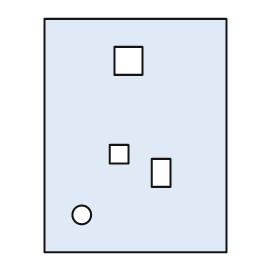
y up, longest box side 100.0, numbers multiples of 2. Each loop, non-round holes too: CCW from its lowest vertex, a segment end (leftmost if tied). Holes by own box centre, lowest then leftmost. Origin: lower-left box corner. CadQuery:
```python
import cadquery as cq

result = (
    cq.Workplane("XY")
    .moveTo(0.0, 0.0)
    .lineTo(78.0, 0.0)
    .lineTo(78.0, 100.0)
    .lineTo(0.0, 100.0)
    .close()
    .moveTo(16.0, 16.0)
    .circle(4.0)
    .moveTo(46.0, 28.0)
    .lineTo(54.0, 28.0)
    .lineTo(54.0, 40.0)
    .lineTo(46.0, 40.0)
    .close()
    .moveTo(28.0, 38.0)
    .lineTo(36.0, 38.0)
    .lineTo(36.0, 46.0)
    .lineTo(28.0, 46.0)
    .close()
    .moveTo(30.0, 76.0)
    .lineTo(42.0, 76.0)
    .lineTo(42.0, 88.0)
    .lineTo(30.0, 88.0)
    .close()
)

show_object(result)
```